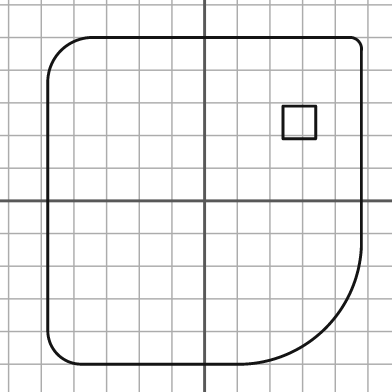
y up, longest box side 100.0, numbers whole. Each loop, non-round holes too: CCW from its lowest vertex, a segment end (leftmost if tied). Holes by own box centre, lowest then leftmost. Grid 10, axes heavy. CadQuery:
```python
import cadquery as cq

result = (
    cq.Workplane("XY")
    .moveTo(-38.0, -50.0)
    .lineTo(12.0, -50.0)
    .threePointArc((37.0, -39.0), (48.0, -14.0))
    .lineTo(48.0, 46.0)
    .threePointArc((47.0, 49.0), (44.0, 50.0))
    .lineTo(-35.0, 50.0)
    .threePointArc((-44.0, 46.0), (-48.0, 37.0))
    .lineTo(-48.0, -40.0)
    .threePointArc((-45.0, -47.0), (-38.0, -50.0))
    .close()
    .moveTo(24.0, 19.0)
    .lineTo(34.0, 19.0)
    .lineTo(34.0, 29.0)
    .lineTo(24.0, 29.0)
    .close()
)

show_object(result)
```